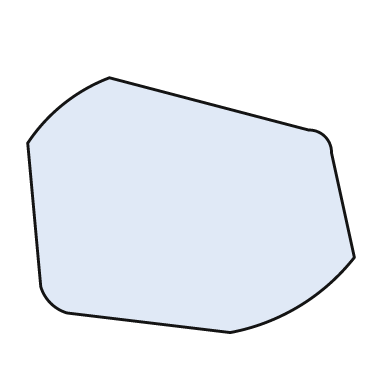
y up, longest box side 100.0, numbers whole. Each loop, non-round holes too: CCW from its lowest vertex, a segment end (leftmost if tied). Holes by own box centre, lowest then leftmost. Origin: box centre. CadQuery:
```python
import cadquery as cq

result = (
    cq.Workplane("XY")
    .moveTo(12.0, -39.0)
    .threePointArc((33.0, -31.0), (50.0, -16.0))
    .lineTo(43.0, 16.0)
    .threePointArc((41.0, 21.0), (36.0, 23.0))
    .lineTo(-25.0, 39.0)
    .threePointArc((-39.0, 31.0), (-50.0, 19.0))
    .lineTo(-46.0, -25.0)
    .threePointArc((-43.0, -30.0), (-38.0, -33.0))
    .close()
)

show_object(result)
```